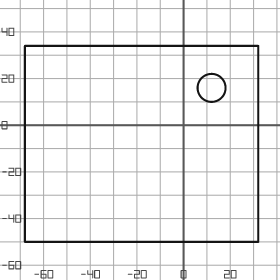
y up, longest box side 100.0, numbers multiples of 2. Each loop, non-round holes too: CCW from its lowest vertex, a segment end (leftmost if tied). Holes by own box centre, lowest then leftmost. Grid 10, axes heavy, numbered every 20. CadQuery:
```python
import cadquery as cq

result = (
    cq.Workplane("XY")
    .moveTo(-68.0, -50.0)
    .lineTo(32.0, -50.0)
    .lineTo(32.0, 34.0)
    .lineTo(-68.0, 34.0)
    .close()
    .moveTo(12.0, 16.0)
    .circle(6.0)
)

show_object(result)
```